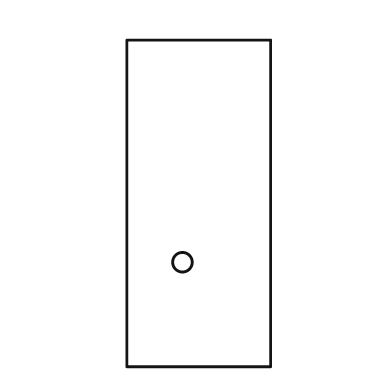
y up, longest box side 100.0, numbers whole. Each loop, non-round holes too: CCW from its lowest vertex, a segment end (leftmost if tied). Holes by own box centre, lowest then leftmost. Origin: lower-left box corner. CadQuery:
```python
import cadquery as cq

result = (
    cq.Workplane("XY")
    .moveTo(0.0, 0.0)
    .lineTo(44.0, 0.0)
    .lineTo(44.0, 100.0)
    .lineTo(0.0, 100.0)
    .close()
    .moveTo(17.0, 32.0)
    .circle(3.0)
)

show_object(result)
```